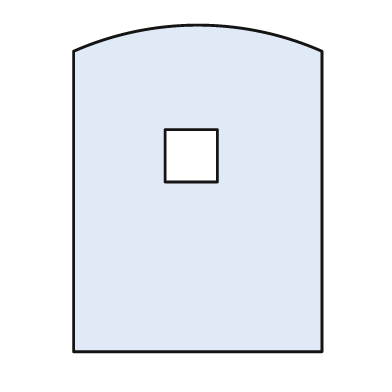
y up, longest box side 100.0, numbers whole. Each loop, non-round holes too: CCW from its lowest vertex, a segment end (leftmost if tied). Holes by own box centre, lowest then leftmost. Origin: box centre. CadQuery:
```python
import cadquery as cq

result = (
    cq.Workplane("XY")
    .moveTo(-38.0, -50.0)
    .lineTo(38.0, -50.0)
    .lineTo(38.0, 42.0)
    .threePointArc((0.0, 50.0), (-38.0, 42.0))
    .close()
    .moveTo(-10.0, 2.0)
    .lineTo(6.0, 2.0)
    .lineTo(6.0, 18.0)
    .lineTo(-10.0, 18.0)
    .close()
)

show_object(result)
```